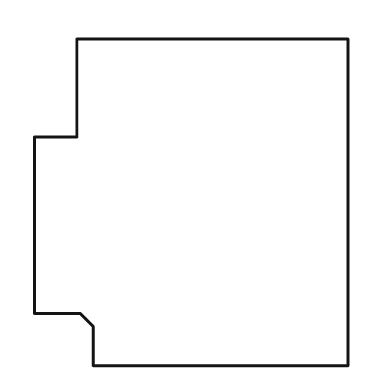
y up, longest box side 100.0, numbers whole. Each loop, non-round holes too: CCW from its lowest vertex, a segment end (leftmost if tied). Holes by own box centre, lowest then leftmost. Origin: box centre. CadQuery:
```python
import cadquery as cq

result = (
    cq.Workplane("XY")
    .moveTo(-30.0, -50.0)
    .lineTo(48.0, -50.0)
    .lineTo(48.0, 50.0)
    .lineTo(-35.0, 50.0)
    .lineTo(-35.0, 20.0)
    .lineTo(-48.0, 20.0)
    .lineTo(-48.0, -34.0)
    .lineTo(-34.0, -34.0)
    .lineTo(-30.0, -38.0)
    .close()
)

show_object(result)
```